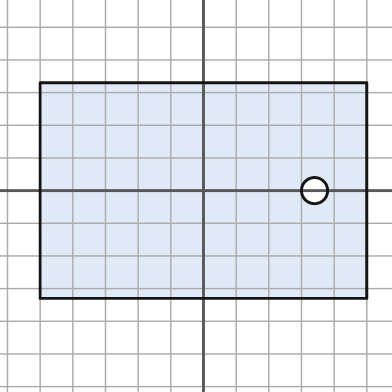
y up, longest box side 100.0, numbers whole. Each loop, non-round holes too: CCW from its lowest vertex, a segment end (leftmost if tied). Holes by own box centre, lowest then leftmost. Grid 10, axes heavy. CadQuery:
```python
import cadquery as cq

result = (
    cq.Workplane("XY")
    .moveTo(-50.0, -33.0)
    .lineTo(50.0, -33.0)
    .lineTo(50.0, 33.0)
    .lineTo(-50.0, 33.0)
    .close()
    .moveTo(34.0, 0.0)
    .circle(4.0)
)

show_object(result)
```